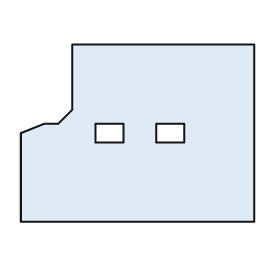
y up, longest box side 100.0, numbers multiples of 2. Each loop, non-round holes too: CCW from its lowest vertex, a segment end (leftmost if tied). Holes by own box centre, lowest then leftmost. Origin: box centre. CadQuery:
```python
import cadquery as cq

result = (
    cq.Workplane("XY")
    .moveTo(-50.0, -38.0)
    .lineTo(50.0, -38.0)
    .lineTo(50.0, 38.0)
    .lineTo(-28.0, 38.0)
    .lineTo(-28.0, 10.0)
    .lineTo(-34.0, 4.0)
    .lineTo(-40.0, 4.0)
    .lineTo(-50.0, 0.0)
    .close()
    .moveTo(-18.0, -4.0)
    .lineTo(-6.0, -4.0)
    .lineTo(-6.0, 4.0)
    .lineTo(-18.0, 4.0)
    .close()
    .moveTo(8.0, -4.0)
    .lineTo(20.0, -4.0)
    .lineTo(20.0, 4.0)
    .lineTo(8.0, 4.0)
    .close()
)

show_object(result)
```